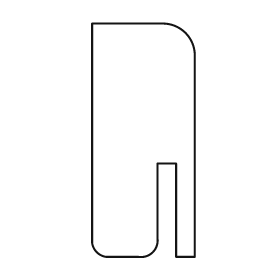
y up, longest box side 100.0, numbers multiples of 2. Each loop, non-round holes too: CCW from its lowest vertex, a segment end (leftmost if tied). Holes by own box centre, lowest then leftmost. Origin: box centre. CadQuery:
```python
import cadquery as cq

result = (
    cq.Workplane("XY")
    .moveTo(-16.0, -50.0)
    .lineTo(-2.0, -50.0)
    .threePointArc((4.0, -48.0), (6.0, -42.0))
    .lineTo(6.0, -10.0)
    .lineTo(14.0, -10.0)
    .lineTo(14.0, -50.0)
    .lineTo(22.0, -50.0)
    .lineTo(22.0, 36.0)
    .threePointArc((18.0, 46.0), (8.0, 50.0))
    .lineTo(-22.0, 50.0)
    .lineTo(-22.0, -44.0)
    .threePointArc((-20.0, -48.0), (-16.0, -50.0))
    .close()
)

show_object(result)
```